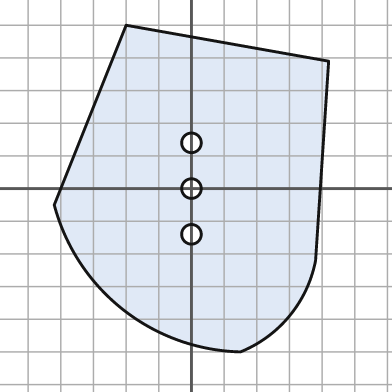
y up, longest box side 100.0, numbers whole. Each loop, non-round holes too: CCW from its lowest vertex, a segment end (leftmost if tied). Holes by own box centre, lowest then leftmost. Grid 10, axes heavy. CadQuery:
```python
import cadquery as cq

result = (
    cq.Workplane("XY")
    .moveTo(15.0, -50.0)
    .threePointArc((30.0, -39.0), (38.0, -22.0))
    .lineTo(42.0, 39.0)
    .lineTo(-20.0, 50.0)
    .lineTo(-42.0, -5.0)
    .threePointArc((-21.0, -37.0), (15.0, -50.0))
    .close()
    .moveTo(0.0, -14.0)
    .circle(3.0)
    .moveTo(0.0, 0.0)
    .circle(3.0)
    .moveTo(0.0, 14.0)
    .circle(3.0)
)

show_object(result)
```